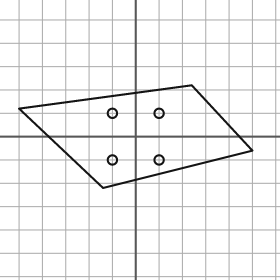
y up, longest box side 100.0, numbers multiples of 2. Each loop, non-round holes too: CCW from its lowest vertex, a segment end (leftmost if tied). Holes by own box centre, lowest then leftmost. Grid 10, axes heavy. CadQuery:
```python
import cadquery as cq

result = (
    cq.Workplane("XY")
    .moveTo(-14.0, -22.0)
    .lineTo(50.0, -6.0)
    .lineTo(24.0, 22.0)
    .lineTo(-50.0, 12.0)
    .close()
    .moveTo(-10.0, -10.0)
    .circle(2.0)
    .moveTo(10.0, -10.0)
    .circle(2.0)
    .moveTo(-10.0, 10.0)
    .circle(2.0)
    .moveTo(10.0, 10.0)
    .circle(2.0)
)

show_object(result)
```